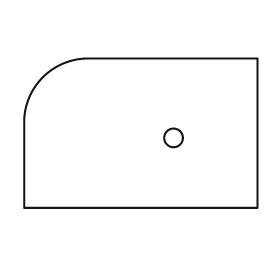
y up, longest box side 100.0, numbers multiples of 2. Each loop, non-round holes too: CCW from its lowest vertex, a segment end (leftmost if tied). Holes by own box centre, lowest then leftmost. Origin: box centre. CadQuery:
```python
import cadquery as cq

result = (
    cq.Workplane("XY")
    .moveTo(-50.0, -32.0)
    .lineTo(50.0, -32.0)
    .lineTo(50.0, 32.0)
    .lineTo(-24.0, 32.0)
    .threePointArc((-42.0, 24.0), (-50.0, 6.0))
    .close()
    .moveTo(14.0, -2.0)
    .circle(4.0)
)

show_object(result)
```